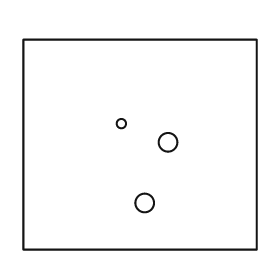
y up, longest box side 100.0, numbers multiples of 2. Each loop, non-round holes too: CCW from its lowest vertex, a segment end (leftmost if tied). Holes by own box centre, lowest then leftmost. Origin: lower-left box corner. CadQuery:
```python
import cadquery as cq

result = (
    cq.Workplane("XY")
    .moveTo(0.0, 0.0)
    .lineTo(100.0, 0.0)
    .lineTo(100.0, 90.0)
    .lineTo(0.0, 90.0)
    .close()
    .moveTo(52.0, 20.0)
    .circle(4.0)
    .moveTo(62.0, 46.0)
    .circle(4.0)
    .moveTo(42.0, 54.0)
    .circle(2.0)
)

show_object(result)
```